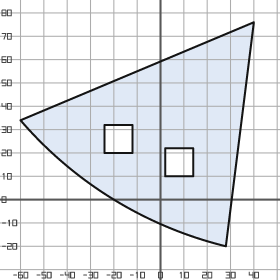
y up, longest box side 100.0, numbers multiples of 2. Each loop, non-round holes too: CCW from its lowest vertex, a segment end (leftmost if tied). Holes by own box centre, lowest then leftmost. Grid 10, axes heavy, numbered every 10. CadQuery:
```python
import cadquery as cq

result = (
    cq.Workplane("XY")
    .moveTo(28.0, -20.0)
    .lineTo(40.0, 76.0)
    .lineTo(-60.0, 34.0)
    .threePointArc((-20.0, 0.0), (28.0, -20.0))
    .close()
    .moveTo(2.0, 10.0)
    .lineTo(14.0, 10.0)
    .lineTo(14.0, 22.0)
    .lineTo(2.0, 22.0)
    .close()
    .moveTo(-24.0, 20.0)
    .lineTo(-12.0, 20.0)
    .lineTo(-12.0, 32.0)
    .lineTo(-24.0, 32.0)
    .close()
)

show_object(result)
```